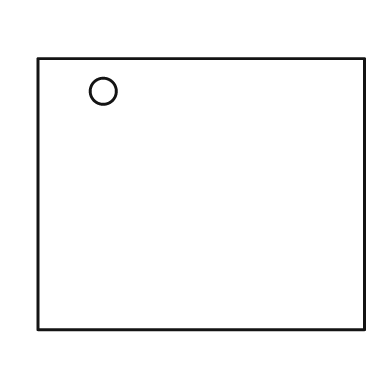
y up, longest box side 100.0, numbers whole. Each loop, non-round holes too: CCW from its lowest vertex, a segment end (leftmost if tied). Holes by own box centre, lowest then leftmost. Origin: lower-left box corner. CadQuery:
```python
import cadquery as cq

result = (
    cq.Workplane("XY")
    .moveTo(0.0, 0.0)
    .lineTo(100.0, 0.0)
    .lineTo(100.0, 83.0)
    .lineTo(0.0, 83.0)
    .close()
    .moveTo(20.0, 73.0)
    .circle(4.0)
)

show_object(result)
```